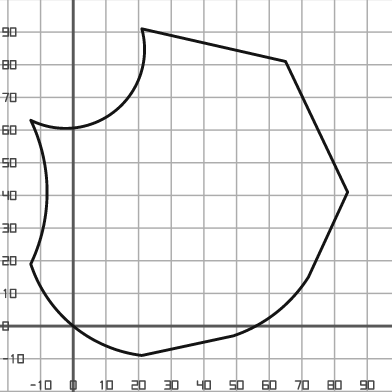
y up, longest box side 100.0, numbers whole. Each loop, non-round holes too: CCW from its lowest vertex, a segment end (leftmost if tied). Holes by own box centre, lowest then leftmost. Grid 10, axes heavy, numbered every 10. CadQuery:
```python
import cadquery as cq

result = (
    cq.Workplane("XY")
    .moveTo(21.0, -9.0)
    .lineTo(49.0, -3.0)
    .threePointArc((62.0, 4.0), (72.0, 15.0))
    .lineTo(84.0, 41.0)
    .lineTo(65.0, 81.0)
    .lineTo(21.0, 91.0)
    .threePointArc((13.0, 66.0), (-13.0, 63.0))
    .threePointArc((-8.0, 41.0), (-13.0, 19.0))
    .threePointArc((0.0, 0.0), (21.0, -9.0))
    .close()
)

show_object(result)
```